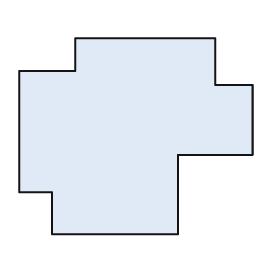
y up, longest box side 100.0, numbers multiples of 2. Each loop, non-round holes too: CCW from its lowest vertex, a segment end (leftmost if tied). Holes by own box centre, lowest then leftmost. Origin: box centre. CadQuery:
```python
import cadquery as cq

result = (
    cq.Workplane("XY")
    .moveTo(-36.0, -42.0)
    .lineTo(18.0, -42.0)
    .lineTo(18.0, -8.0)
    .lineTo(50.0, -8.0)
    .lineTo(50.0, 22.0)
    .lineTo(34.0, 22.0)
    .lineTo(34.0, 42.0)
    .lineTo(-26.0, 42.0)
    .lineTo(-26.0, 28.0)
    .lineTo(-50.0, 28.0)
    .lineTo(-50.0, -24.0)
    .lineTo(-36.0, -24.0)
    .close()
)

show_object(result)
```